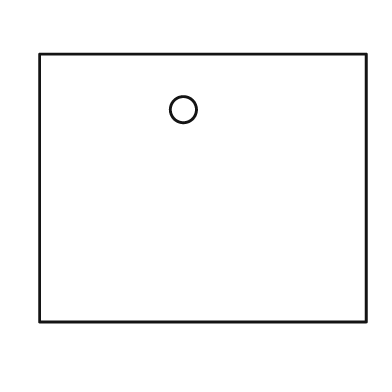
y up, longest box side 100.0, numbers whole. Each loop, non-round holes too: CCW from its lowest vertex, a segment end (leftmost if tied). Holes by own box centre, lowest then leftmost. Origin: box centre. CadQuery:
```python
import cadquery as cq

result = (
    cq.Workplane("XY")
    .moveTo(-50.0, -41.0)
    .lineTo(50.0, -41.0)
    .lineTo(50.0, 41.0)
    .lineTo(-50.0, 41.0)
    .close()
    .moveTo(-6.0, 24.0)
    .circle(4.0)
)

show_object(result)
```